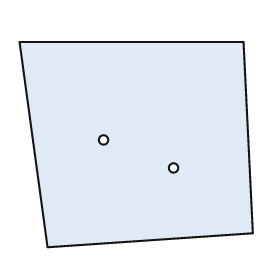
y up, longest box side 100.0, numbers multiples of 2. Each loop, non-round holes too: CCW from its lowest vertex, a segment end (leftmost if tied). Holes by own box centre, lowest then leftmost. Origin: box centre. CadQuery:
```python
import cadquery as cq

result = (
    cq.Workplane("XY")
    .moveTo(-38.0, -44.0)
    .lineTo(50.0, -38.0)
    .lineTo(46.0, 44.0)
    .lineTo(-50.0, 44.0)
    .close()
    .moveTo(16.0, -10.0)
    .circle(2.0)
    .moveTo(-14.0, 2.0)
    .circle(2.0)
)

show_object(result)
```